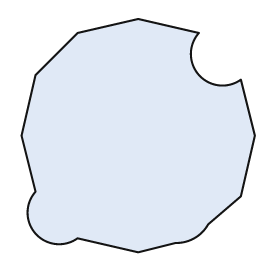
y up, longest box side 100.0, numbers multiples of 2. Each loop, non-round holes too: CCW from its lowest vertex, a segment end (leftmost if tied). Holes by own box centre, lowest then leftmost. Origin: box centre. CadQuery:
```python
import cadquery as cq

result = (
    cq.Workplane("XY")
    .moveTo(0.0, -50.0)
    .lineTo(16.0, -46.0)
    .threePointArc((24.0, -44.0), (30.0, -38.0))
    .lineTo(44.0, -26.0)
    .lineTo(50.0, 0.0)
    .lineTo(44.0, 24.0)
    .threePointArc((26.0, 26.0), (26.0, 44.0))
    .lineTo(0.0, 50.0)
    .lineTo(-26.0, 44.0)
    .lineTo(-44.0, 26.0)
    .lineTo(-50.0, 0.0)
    .lineTo(-44.0, -24.0)
    .threePointArc((-44.0, -42.0), (-26.0, -44.0))
    .close()
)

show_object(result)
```